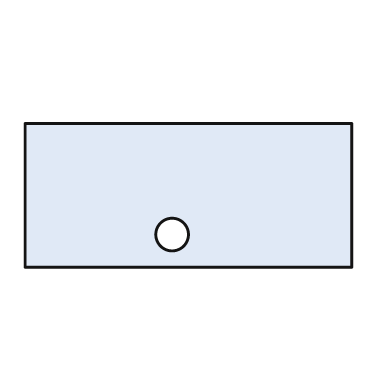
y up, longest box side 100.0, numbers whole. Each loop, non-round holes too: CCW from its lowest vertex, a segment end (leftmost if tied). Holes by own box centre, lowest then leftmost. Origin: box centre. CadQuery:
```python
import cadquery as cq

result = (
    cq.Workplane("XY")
    .moveTo(-50.0, -22.0)
    .lineTo(50.0, -22.0)
    .lineTo(50.0, 22.0)
    .lineTo(-50.0, 22.0)
    .close()
    .moveTo(-5.0, -12.0)
    .circle(5.0)
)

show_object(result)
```